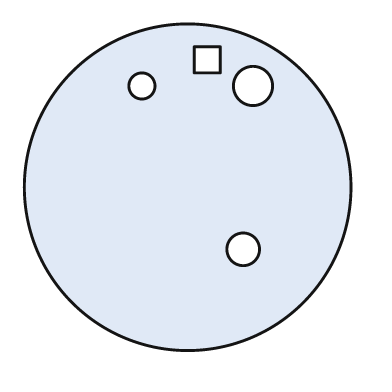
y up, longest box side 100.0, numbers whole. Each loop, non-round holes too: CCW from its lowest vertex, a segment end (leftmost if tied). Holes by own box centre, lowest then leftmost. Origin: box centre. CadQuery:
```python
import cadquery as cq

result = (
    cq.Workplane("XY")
    .moveTo(0.0, 0.0)
    .circle(50.0)
    .moveTo(17.0, -19.0)
    .circle(5.0)
    .moveTo(-14.0, 31.0)
    .circle(4.0)
    .moveTo(20.0, 31.0)
    .circle(6.0)
    .moveTo(2.0, 35.0)
    .lineTo(10.0, 35.0)
    .lineTo(10.0, 43.0)
    .lineTo(2.0, 43.0)
    .close()
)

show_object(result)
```